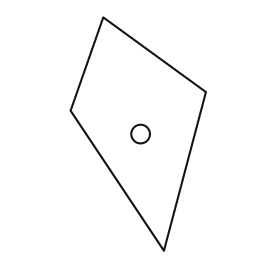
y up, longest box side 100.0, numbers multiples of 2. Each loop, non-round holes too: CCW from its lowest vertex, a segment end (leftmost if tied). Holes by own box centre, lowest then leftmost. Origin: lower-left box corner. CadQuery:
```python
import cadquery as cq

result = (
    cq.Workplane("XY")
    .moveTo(40.0, 0.0)
    .lineTo(58.0, 68.0)
    .lineTo(14.0, 100.0)
    .lineTo(0.0, 60.0)
    .close()
    .moveTo(30.0, 50.0)
    .circle(4.0)
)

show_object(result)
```